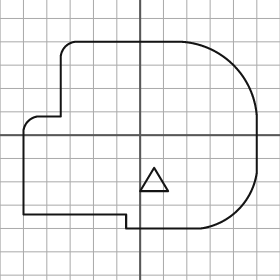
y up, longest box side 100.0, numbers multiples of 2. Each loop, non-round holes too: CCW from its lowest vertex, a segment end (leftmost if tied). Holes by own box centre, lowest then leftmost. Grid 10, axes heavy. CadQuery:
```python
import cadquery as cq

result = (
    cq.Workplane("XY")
    .moveTo(-6.0, -40.0)
    .lineTo(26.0, -40.0)
    .threePointArc((42.0, -32.0), (50.0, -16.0))
    .lineTo(50.0, 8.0)
    .threePointArc((40.0, 30.0), (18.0, 40.0))
    .lineTo(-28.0, 40.0)
    .threePointArc((-32.0, 38.0), (-34.0, 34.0))
    .lineTo(-34.0, 8.0)
    .lineTo(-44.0, 8.0)
    .threePointArc((-48.0, 6.0), (-50.0, 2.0))
    .lineTo(-50.0, -34.0)
    .lineTo(-6.0, -34.0)
    .close()
    .moveTo(0.0, -24.0)
    .lineTo(12.0, -24.0)
    .lineTo(6.0, -14.0)
    .close()
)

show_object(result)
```